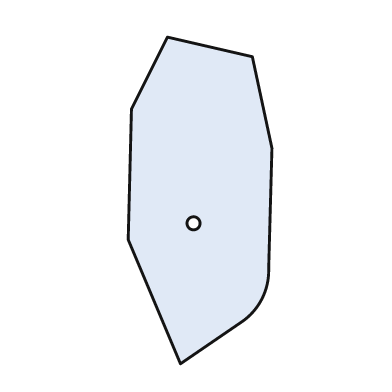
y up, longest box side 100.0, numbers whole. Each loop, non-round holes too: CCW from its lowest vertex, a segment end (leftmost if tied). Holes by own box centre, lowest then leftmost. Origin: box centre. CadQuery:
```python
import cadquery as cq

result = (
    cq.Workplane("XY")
    .moveTo(-6.0, -50.0)
    .lineTo(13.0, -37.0)
    .threePointArc((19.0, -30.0), (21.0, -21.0))
    .lineTo(22.0, 16.0)
    .lineTo(16.0, 44.0)
    .lineTo(-10.0, 50.0)
    .lineTo(-21.0, 28.0)
    .lineTo(-22.0, -12.0)
    .close()
    .moveTo(-2.0, -7.0)
    .circle(2.0)
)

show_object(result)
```